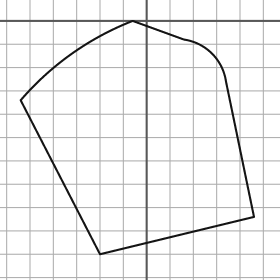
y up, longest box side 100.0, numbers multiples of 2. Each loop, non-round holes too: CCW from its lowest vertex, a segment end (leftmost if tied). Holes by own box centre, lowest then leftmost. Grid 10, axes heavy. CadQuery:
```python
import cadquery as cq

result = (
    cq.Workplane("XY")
    .moveTo(-20.0, -100.0)
    .lineTo(46.0, -84.0)
    .lineTo(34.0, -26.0)
    .threePointArc((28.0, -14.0), (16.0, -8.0))
    .lineTo(-6.0, 0.0)
    .threePointArc((-32.0, -14.0), (-54.0, -34.0))
    .close()
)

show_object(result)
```